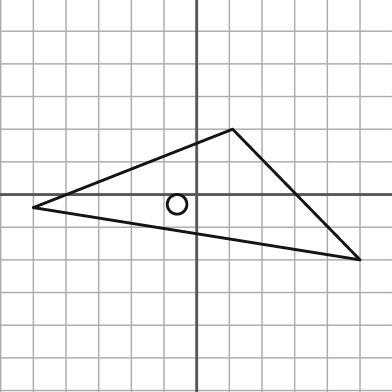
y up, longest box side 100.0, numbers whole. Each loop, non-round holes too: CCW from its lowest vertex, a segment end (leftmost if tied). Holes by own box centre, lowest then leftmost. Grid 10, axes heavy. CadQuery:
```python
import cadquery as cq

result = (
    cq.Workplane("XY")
    .moveTo(50.0, -20.0)
    .lineTo(11.0, 20.0)
    .lineTo(-50.0, -4.0)
    .close()
    .moveTo(-6.0, -3.0)
    .circle(3.0)
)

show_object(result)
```